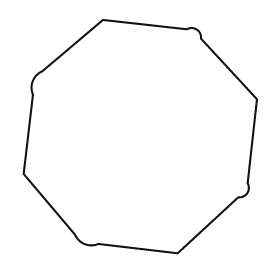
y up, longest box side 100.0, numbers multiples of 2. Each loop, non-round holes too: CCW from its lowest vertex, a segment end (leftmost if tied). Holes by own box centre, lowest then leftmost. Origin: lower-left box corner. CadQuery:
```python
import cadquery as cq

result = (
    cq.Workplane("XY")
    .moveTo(66.0, 0.0)
    .lineTo(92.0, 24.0)
    .threePointArc((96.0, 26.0), (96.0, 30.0))
    .lineTo(100.0, 66.0)
    .lineTo(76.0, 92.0)
    .threePointArc((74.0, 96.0), (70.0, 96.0))
    .lineTo(34.0, 100.0)
    .lineTo(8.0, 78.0)
    .threePointArc((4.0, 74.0), (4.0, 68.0))
    .lineTo(0.0, 34.0)
    .lineTo(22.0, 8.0)
    .threePointArc((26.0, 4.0), (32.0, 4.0))
    .close()
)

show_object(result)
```